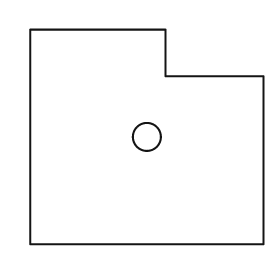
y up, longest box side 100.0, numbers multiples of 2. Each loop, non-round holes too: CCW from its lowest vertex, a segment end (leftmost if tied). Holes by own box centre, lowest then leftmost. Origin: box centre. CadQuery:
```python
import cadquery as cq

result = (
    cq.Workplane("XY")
    .moveTo(-50.0, -46.0)
    .lineTo(50.0, -46.0)
    .lineTo(50.0, 26.0)
    .lineTo(8.0, 26.0)
    .lineTo(8.0, 46.0)
    .lineTo(-50.0, 46.0)
    .close()
    .moveTo(0.0, 0.0)
    .circle(6.0)
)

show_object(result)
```